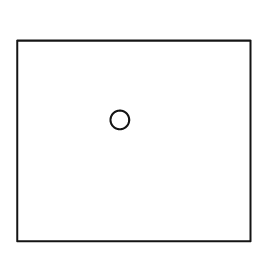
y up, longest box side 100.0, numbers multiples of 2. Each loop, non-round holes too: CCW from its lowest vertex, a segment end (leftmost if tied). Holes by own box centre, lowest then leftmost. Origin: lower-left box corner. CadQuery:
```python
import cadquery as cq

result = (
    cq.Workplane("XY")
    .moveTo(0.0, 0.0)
    .lineTo(100.0, 0.0)
    .lineTo(100.0, 86.0)
    .lineTo(0.0, 86.0)
    .close()
    .moveTo(44.0, 52.0)
    .circle(4.0)
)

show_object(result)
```